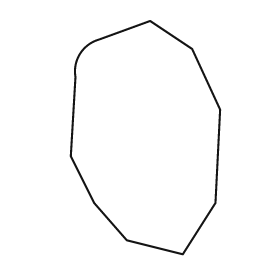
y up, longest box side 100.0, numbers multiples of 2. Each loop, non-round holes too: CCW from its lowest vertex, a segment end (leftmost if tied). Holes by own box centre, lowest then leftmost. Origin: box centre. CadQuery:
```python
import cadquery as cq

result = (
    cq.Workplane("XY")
    .moveTo(16.0, -50.0)
    .lineTo(30.0, -28.0)
    .lineTo(32.0, 12.0)
    .lineTo(20.0, 38.0)
    .lineTo(2.0, 50.0)
    .lineTo(-20.0, 42.0)
    .threePointArc((-28.0, 36.0), (-30.0, 26.0))
    .lineTo(-32.0, -8.0)
    .lineTo(-22.0, -28.0)
    .lineTo(-8.0, -44.0)
    .close()
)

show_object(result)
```